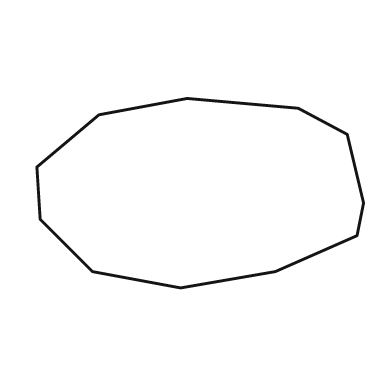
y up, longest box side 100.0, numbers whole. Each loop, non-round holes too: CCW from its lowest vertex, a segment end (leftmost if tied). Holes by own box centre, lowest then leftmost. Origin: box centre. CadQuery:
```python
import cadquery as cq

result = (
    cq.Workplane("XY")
    .moveTo(-6.0, -29.0)
    .lineTo(23.0, -24.0)
    .lineTo(48.0, -13.0)
    .lineTo(50.0, -3.0)
    .lineTo(45.0, 18.0)
    .lineTo(30.0, 26.0)
    .lineTo(-4.0, 29.0)
    .lineTo(-31.0, 24.0)
    .lineTo(-50.0, 8.0)
    .lineTo(-49.0, -8.0)
    .lineTo(-33.0, -24.0)
    .close()
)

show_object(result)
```